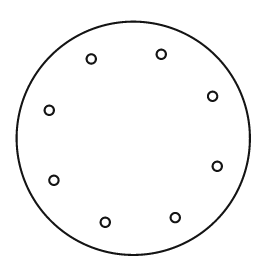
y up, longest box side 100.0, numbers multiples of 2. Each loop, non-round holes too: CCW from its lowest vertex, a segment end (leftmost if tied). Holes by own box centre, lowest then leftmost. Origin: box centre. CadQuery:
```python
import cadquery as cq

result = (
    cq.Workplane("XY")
    .moveTo(0.0, 0.0)
    .circle(50.0)
    .moveTo(-12.0, -36.0)
    .circle(2.0)
    .moveTo(18.0, -34.0)
    .circle(2.0)
    .moveTo(-34.0, -18.0)
    .circle(2.0)
    .moveTo(36.0, -12.0)
    .circle(2.0)
    .moveTo(-36.0, 12.0)
    .circle(2.0)
    .moveTo(34.0, 18.0)
    .circle(2.0)
    .moveTo(-18.0, 34.0)
    .circle(2.0)
    .moveTo(12.0, 36.0)
    .circle(2.0)
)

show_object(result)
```